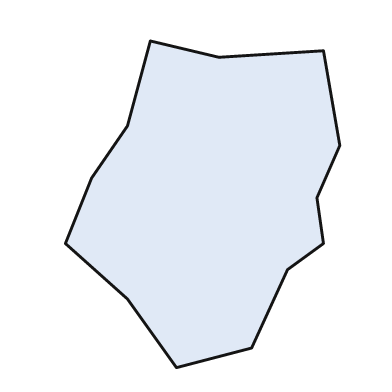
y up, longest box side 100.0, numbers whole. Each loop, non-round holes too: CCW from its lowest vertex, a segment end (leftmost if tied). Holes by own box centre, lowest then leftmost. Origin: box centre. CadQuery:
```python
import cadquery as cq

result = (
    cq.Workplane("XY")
    .moveTo(-8.0, -50.0)
    .lineTo(15.0, -44.0)
    .lineTo(26.0, -20.0)
    .lineTo(37.0, -12.0)
    .lineTo(35.0, 2.0)
    .lineTo(42.0, 18.0)
    .lineTo(37.0, 47.0)
    .lineTo(5.0, 45.0)
    .lineTo(-16.0, 50.0)
    .lineTo(-23.0, 24.0)
    .lineTo(-34.0, 8.0)
    .lineTo(-42.0, -12.0)
    .lineTo(-23.0, -29.0)
    .close()
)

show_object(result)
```